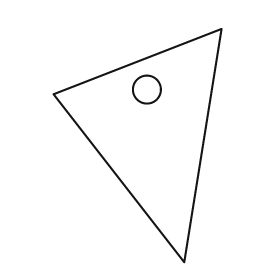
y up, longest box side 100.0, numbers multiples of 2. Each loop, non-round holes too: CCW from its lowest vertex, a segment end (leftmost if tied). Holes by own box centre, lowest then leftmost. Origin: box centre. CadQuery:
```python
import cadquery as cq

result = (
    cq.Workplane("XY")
    .moveTo(20.0, -50.0)
    .lineTo(36.0, 50.0)
    .lineTo(-36.0, 22.0)
    .close()
    .moveTo(4.0, 24.0)
    .circle(6.0)
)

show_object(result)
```